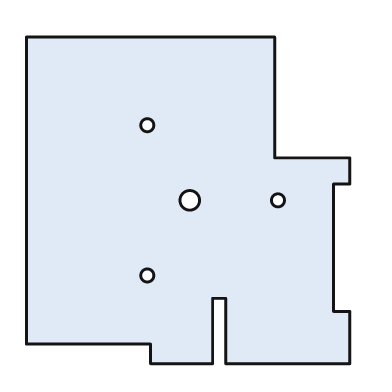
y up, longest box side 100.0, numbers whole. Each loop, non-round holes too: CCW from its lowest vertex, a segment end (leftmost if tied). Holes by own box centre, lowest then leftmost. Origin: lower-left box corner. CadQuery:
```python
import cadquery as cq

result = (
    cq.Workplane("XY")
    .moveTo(38.0, 0.0)
    .lineTo(57.0, 0.0)
    .lineTo(57.0, 20.0)
    .lineTo(61.0, 20.0)
    .lineTo(61.0, 0.0)
    .lineTo(99.0, 0.0)
    .lineTo(99.0, 16.0)
    .lineTo(94.0, 16.0)
    .lineTo(94.0, 55.0)
    .lineTo(99.0, 55.0)
    .lineTo(99.0, 63.0)
    .lineTo(76.0, 63.0)
    .lineTo(76.0, 100.0)
    .lineTo(0.0, 100.0)
    .lineTo(0.0, 6.0)
    .lineTo(38.0, 6.0)
    .close()
    .moveTo(37.0, 27.0)
    .circle(2.0)
    .moveTo(50.0, 50.0)
    .circle(3.0)
    .moveTo(77.0, 50.0)
    .circle(2.0)
    .moveTo(37.0, 73.0)
    .circle(2.0)
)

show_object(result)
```